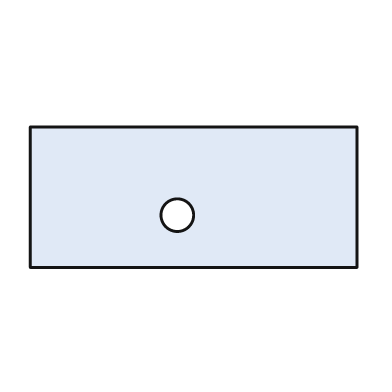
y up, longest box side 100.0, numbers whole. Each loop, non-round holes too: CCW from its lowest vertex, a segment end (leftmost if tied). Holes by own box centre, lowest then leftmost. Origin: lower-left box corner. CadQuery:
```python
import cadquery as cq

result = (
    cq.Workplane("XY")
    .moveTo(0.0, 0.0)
    .lineTo(100.0, 0.0)
    .lineTo(100.0, 43.0)
    .lineTo(0.0, 43.0)
    .close()
    .moveTo(45.0, 16.0)
    .circle(5.0)
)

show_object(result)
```